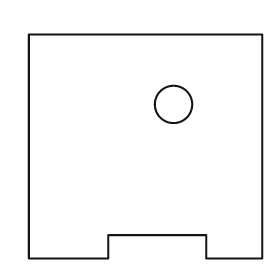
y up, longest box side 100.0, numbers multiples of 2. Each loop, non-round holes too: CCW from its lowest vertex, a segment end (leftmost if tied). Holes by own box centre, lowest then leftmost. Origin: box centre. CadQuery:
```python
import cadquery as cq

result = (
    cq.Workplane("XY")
    .moveTo(-50.0, -48.0)
    .lineTo(-16.0, -48.0)
    .lineTo(-16.0, -38.0)
    .lineTo(26.0, -38.0)
    .lineTo(26.0, -48.0)
    .lineTo(50.0, -48.0)
    .lineTo(50.0, 48.0)
    .lineTo(-50.0, 48.0)
    .close()
    .moveTo(12.0, 18.0)
    .circle(8.0)
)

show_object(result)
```